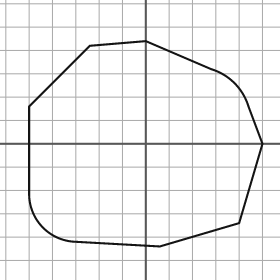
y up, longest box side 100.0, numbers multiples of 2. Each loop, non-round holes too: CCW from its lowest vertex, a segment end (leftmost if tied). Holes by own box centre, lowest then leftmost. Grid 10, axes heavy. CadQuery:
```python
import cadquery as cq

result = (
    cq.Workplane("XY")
    .moveTo(6.0, -44.0)
    .lineTo(40.0, -34.0)
    .lineTo(50.0, 0.0)
    .lineTo(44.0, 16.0)
    .threePointArc((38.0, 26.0), (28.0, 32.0))
    .lineTo(0.0, 44.0)
    .lineTo(-24.0, 42.0)
    .lineTo(-50.0, 16.0)
    .lineTo(-50.0, -22.0)
    .threePointArc((-44.0, -36.0), (-30.0, -42.0))
    .close()
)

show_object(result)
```